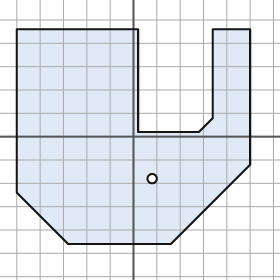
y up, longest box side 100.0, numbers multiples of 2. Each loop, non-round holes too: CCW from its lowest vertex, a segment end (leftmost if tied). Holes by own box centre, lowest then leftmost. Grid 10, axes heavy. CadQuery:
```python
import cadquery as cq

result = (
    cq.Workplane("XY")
    .moveTo(-28.0, -46.0)
    .lineTo(16.0, -46.0)
    .lineTo(50.0, -12.0)
    .lineTo(50.0, 46.0)
    .lineTo(34.0, 46.0)
    .lineTo(34.0, 8.0)
    .lineTo(28.0, 2.0)
    .lineTo(2.0, 2.0)
    .lineTo(2.0, 46.0)
    .lineTo(-50.0, 46.0)
    .lineTo(-50.0, -24.0)
    .close()
    .moveTo(8.0, -18.0)
    .circle(2.0)
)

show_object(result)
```